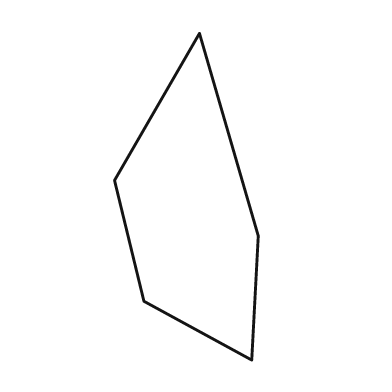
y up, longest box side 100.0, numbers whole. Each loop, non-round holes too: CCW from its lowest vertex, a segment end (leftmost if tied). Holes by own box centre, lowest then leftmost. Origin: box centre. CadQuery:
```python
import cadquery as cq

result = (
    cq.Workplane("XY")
    .moveTo(20.0, -50.0)
    .lineTo(22.0, -12.0)
    .lineTo(4.0, 50.0)
    .lineTo(-22.0, 5.0)
    .lineTo(-13.0, -32.0)
    .close()
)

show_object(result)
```